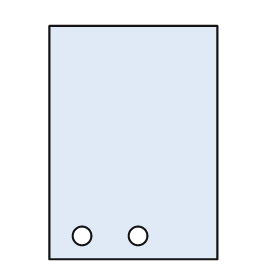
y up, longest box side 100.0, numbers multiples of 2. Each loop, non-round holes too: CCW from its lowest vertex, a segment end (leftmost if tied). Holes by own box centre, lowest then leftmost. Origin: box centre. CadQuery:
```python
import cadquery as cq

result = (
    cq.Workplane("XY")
    .moveTo(-36.0, -50.0)
    .lineTo(36.0, -50.0)
    .lineTo(36.0, 50.0)
    .lineTo(-36.0, 50.0)
    .close()
    .moveTo(-22.0, -40.0)
    .circle(4.0)
    .moveTo(2.0, -40.0)
    .circle(4.0)
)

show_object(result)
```